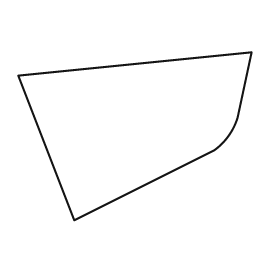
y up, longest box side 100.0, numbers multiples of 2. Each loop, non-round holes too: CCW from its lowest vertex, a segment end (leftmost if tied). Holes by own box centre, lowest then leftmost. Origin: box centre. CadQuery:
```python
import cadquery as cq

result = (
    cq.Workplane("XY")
    .moveTo(-26.0, -36.0)
    .lineTo(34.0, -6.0)
    .threePointArc((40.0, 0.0), (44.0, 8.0))
    .lineTo(50.0, 36.0)
    .lineTo(-50.0, 26.0)
    .close()
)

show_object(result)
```